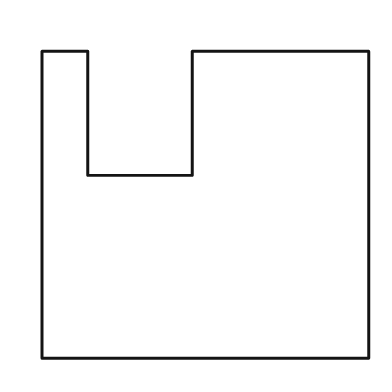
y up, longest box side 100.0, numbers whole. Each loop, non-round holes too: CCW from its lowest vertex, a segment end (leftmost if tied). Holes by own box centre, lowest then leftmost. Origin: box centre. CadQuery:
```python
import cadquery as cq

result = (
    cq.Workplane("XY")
    .moveTo(-50.0, -47.0)
    .lineTo(50.0, -47.0)
    .lineTo(50.0, 47.0)
    .lineTo(-4.0, 47.0)
    .lineTo(-4.0, 9.0)
    .lineTo(-36.0, 9.0)
    .lineTo(-36.0, 47.0)
    .lineTo(-50.0, 47.0)
    .close()
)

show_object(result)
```